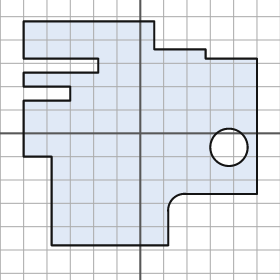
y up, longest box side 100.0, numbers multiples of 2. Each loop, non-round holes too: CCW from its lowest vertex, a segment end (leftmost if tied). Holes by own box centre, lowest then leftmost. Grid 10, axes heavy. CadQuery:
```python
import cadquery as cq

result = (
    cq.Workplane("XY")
    .moveTo(-38.0, -48.0)
    .lineTo(12.0, -48.0)
    .lineTo(12.0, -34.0)
    .threePointArc((14.0, -28.0), (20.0, -26.0))
    .lineTo(50.0, -26.0)
    .lineTo(50.0, 32.0)
    .lineTo(28.0, 32.0)
    .lineTo(28.0, 36.0)
    .lineTo(6.0, 36.0)
    .lineTo(6.0, 48.0)
    .lineTo(-50.0, 48.0)
    .lineTo(-50.0, 32.0)
    .lineTo(-18.0, 32.0)
    .lineTo(-18.0, 26.0)
    .lineTo(-50.0, 26.0)
    .lineTo(-50.0, 20.0)
    .lineTo(-30.0, 20.0)
    .lineTo(-30.0, 14.0)
    .lineTo(-50.0, 14.0)
    .lineTo(-50.0, -10.0)
    .lineTo(-38.0, -10.0)
    .close()
    .moveTo(38.0, -6.0)
    .circle(8.0)
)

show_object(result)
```